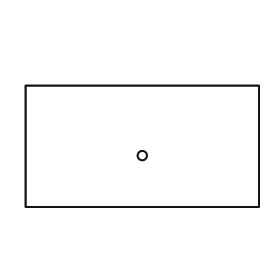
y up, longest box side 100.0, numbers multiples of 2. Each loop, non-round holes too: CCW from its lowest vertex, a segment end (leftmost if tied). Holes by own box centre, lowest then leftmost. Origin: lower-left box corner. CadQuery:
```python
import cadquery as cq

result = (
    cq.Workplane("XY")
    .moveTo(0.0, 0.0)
    .lineTo(100.0, 0.0)
    .lineTo(100.0, 52.0)
    .lineTo(0.0, 52.0)
    .close()
    .moveTo(50.0, 22.0)
    .circle(2.0)
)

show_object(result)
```